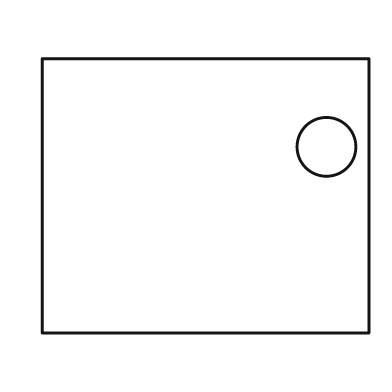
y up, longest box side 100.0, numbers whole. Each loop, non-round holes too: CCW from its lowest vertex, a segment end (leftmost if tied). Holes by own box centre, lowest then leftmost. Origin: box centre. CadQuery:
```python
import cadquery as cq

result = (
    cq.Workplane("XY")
    .moveTo(-50.0, -42.0)
    .lineTo(50.0, -42.0)
    .lineTo(50.0, 42.0)
    .lineTo(-50.0, 42.0)
    .close()
    .moveTo(37.0, 15.0)
    .circle(9.0)
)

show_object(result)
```